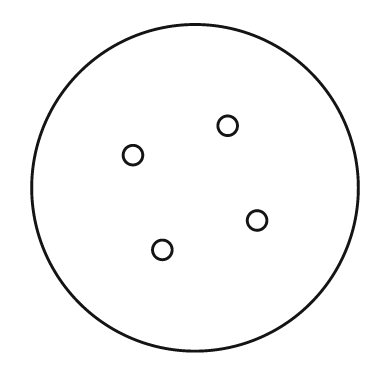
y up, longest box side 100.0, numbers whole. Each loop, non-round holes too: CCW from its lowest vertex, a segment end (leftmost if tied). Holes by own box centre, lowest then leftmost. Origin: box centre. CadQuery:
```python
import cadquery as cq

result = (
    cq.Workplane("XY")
    .moveTo(0.0, 0.0)
    .circle(50.0)
    .moveTo(-10.0, -19.0)
    .circle(3.0)
    .moveTo(19.0, -10.0)
    .circle(3.0)
    .moveTo(-19.0, 10.0)
    .circle(3.0)
    .moveTo(10.0, 19.0)
    .circle(3.0)
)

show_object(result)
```